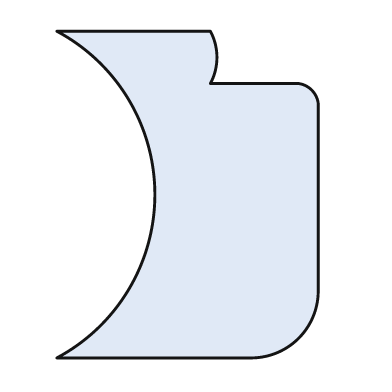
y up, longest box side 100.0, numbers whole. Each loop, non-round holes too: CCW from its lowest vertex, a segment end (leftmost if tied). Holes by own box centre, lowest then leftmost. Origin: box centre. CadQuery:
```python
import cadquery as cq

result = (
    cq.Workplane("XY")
    .moveTo(-40.0, -50.0)
    .lineTo(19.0, -50.0)
    .threePointArc((34.0, -44.0), (40.0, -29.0))
    .lineTo(40.0, 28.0)
    .threePointArc((38.0, 32.0), (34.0, 34.0))
    .lineTo(7.0, 34.0)
    .threePointArc((9.0, 42.0), (7.0, 50.0))
    .lineTo(-40.0, 50.0)
    .threePointArc((-10.0, 0.0), (-40.0, -50.0))
    .close()
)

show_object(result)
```